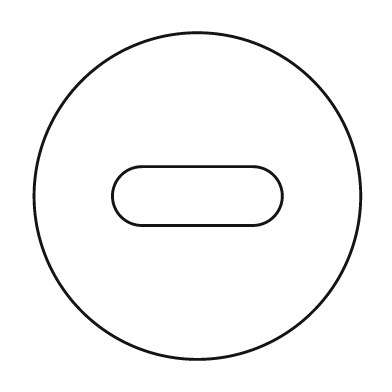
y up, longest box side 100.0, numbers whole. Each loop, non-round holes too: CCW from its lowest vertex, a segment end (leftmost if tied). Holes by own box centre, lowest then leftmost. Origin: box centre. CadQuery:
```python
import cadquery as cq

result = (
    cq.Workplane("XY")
    .moveTo(0.0, 0.0)
    .circle(50.0)
    .moveTo(-17.0, -9.0)
    .lineTo(17.0, -9.0)
    .threePointArc((26.0, 0.0), (17.0, 9.0))
    .lineTo(-17.0, 9.0)
    .threePointArc((-26.0, 0.0), (-17.0, -9.0))
    .close()
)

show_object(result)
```